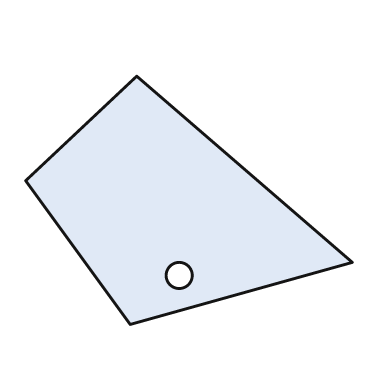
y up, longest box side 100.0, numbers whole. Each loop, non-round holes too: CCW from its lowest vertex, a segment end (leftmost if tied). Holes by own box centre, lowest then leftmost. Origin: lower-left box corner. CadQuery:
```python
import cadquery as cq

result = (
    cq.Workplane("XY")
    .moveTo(32.0, 0.0)
    .lineTo(100.0, 19.0)
    .lineTo(34.0, 76.0)
    .lineTo(0.0, 44.0)
    .close()
    .moveTo(47.0, 15.0)
    .circle(4.0)
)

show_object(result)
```